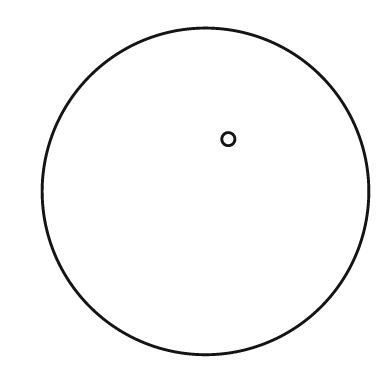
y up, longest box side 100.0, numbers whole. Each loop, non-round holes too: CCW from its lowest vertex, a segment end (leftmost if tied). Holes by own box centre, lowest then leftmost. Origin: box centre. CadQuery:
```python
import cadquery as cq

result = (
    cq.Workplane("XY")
    .moveTo(0.0, 0.0)
    .circle(50.0)
    .moveTo(7.0, 16.0)
    .circle(2.0)
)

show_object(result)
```